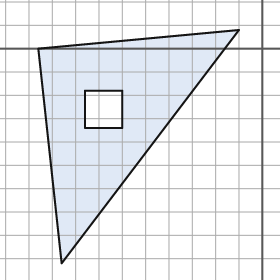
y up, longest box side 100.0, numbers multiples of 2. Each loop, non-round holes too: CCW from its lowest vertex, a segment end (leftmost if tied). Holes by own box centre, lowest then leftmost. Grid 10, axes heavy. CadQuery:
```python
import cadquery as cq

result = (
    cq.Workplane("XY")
    .moveTo(-86.0, -92.0)
    .lineTo(-10.0, 8.0)
    .lineTo(-96.0, 0.0)
    .close()
    .moveTo(-76.0, -34.0)
    .lineTo(-60.0, -34.0)
    .lineTo(-60.0, -18.0)
    .lineTo(-76.0, -18.0)
    .close()
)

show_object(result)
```